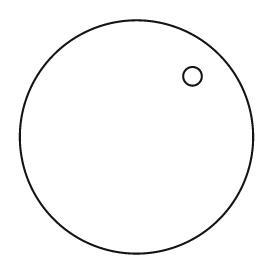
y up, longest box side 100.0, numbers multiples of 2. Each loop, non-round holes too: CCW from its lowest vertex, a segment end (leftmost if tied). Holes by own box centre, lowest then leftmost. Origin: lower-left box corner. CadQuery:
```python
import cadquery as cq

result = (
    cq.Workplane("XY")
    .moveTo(50.0, 50.0)
    .circle(50.0)
    .moveTo(74.0, 76.0)
    .circle(4.0)
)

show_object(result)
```